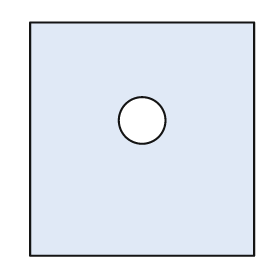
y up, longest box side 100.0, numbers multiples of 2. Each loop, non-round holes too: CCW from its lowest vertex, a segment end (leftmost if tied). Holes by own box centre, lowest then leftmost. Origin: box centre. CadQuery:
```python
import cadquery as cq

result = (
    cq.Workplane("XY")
    .moveTo(-48.0, -50.0)
    .lineTo(48.0, -50.0)
    .lineTo(48.0, 50.0)
    .lineTo(-48.0, 50.0)
    .close()
    .moveTo(0.0, 8.0)
    .circle(10.0)
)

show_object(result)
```